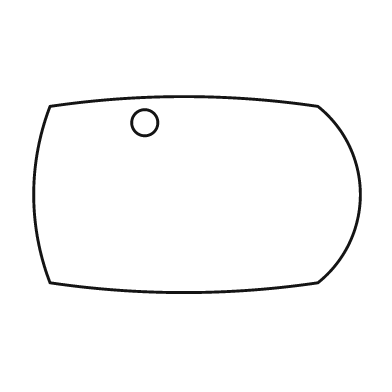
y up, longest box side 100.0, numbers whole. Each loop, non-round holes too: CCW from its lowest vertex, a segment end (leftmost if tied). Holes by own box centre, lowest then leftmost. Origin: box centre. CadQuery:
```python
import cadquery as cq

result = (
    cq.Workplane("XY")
    .moveTo(-45.0, -27.0)
    .threePointArc((-4.0, -30.0), (37.0, -27.0))
    .threePointArc((50.0, 0.0), (37.0, 27.0))
    .threePointArc((-4.0, 30.0), (-45.0, 27.0))
    .threePointArc((-50.0, 0.0), (-45.0, -27.0))
    .close()
    .moveTo(-16.0, 22.0)
    .circle(4.0)
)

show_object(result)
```